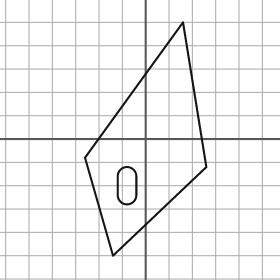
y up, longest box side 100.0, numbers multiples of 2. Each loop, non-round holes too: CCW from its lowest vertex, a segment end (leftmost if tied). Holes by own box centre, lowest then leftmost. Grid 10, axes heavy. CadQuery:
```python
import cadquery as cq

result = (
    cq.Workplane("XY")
    .moveTo(-14.0, -50.0)
    .lineTo(26.0, -12.0)
    .lineTo(16.0, 50.0)
    .lineTo(-26.0, -8.0)
    .close()
    .moveTo(-12.0, -24.0)
    .threePointArc((-8.0, -28.0), (-4.0, -24.0))
    .lineTo(-4.0, -16.0)
    .threePointArc((-8.0, -12.0), (-12.0, -16.0))
    .close()
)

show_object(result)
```